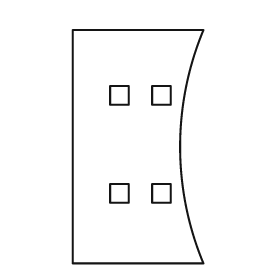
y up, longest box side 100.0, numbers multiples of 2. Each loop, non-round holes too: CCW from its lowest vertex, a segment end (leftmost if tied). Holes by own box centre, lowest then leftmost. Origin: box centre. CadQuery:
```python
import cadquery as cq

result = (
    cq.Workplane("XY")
    .moveTo(-28.0, -50.0)
    .lineTo(28.0, -50.0)
    .threePointArc((18.0, 0.0), (28.0, 50.0))
    .lineTo(-28.0, 50.0)
    .close()
    .moveTo(-12.0, -24.0)
    .lineTo(-4.0, -24.0)
    .lineTo(-4.0, -16.0)
    .lineTo(-12.0, -16.0)
    .close()
    .moveTo(6.0, -24.0)
    .lineTo(14.0, -24.0)
    .lineTo(14.0, -16.0)
    .lineTo(6.0, -16.0)
    .close()
    .moveTo(-12.0, 18.0)
    .lineTo(-4.0, 18.0)
    .lineTo(-4.0, 26.0)
    .lineTo(-12.0, 26.0)
    .close()
    .moveTo(6.0, 18.0)
    .lineTo(14.0, 18.0)
    .lineTo(14.0, 26.0)
    .lineTo(6.0, 26.0)
    .close()
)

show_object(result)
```